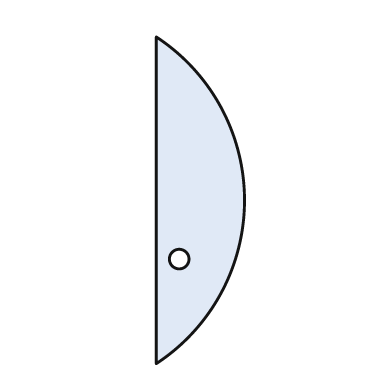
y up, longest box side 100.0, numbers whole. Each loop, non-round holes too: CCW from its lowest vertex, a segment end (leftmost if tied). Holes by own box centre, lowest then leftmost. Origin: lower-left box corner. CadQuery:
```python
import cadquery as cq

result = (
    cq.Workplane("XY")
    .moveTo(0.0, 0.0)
    .threePointArc((27.0, 50.0), (0.0, 100.0))
    .close()
    .moveTo(7.0, 32.0)
    .circle(3.0)
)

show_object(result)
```